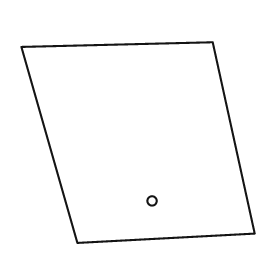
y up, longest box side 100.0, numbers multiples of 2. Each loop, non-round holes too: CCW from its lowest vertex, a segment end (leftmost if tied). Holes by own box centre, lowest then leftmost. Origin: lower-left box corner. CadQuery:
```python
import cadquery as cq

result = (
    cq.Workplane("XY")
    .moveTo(24.0, 0.0)
    .lineTo(100.0, 4.0)
    .lineTo(82.0, 86.0)
    .lineTo(0.0, 84.0)
    .close()
    .moveTo(56.0, 18.0)
    .circle(2.0)
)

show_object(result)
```